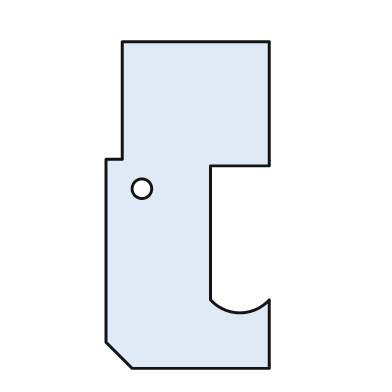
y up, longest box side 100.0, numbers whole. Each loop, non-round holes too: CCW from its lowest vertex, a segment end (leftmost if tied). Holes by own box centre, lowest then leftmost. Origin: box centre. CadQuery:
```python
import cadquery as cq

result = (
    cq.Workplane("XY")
    .moveTo(-17.0, -50.0)
    .lineTo(25.0, -50.0)
    .lineTo(25.0, -29.0)
    .threePointArc((16.0, -33.0), (7.0, -29.0))
    .lineTo(7.0, 12.0)
    .lineTo(25.0, 12.0)
    .lineTo(25.0, 50.0)
    .lineTo(-20.0, 50.0)
    .lineTo(-20.0, 14.0)
    .lineTo(-25.0, 14.0)
    .lineTo(-25.0, -42.0)
    .close()
    .moveTo(-14.0, 5.0)
    .circle(3.0)
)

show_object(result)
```